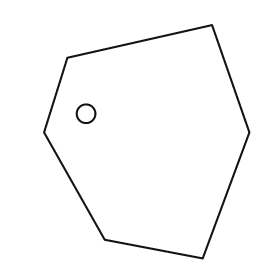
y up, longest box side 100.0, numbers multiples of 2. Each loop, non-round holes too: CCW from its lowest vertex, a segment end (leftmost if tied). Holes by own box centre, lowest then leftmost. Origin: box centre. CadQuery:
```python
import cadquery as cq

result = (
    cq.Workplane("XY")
    .moveTo(24.0, -50.0)
    .lineTo(44.0, 4.0)
    .lineTo(28.0, 50.0)
    .lineTo(-34.0, 36.0)
    .lineTo(-44.0, 4.0)
    .lineTo(-18.0, -42.0)
    .close()
    .moveTo(-26.0, 12.0)
    .circle(4.0)
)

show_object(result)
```